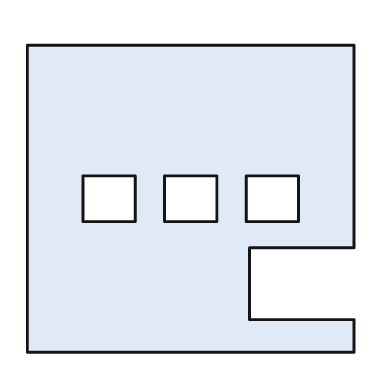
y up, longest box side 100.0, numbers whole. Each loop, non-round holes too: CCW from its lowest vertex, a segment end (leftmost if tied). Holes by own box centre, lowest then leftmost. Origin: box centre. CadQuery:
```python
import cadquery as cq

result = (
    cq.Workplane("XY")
    .moveTo(-50.0, -47.0)
    .lineTo(50.0, -47.0)
    .lineTo(50.0, -37.0)
    .lineTo(18.0, -37.0)
    .lineTo(18.0, -15.0)
    .lineTo(50.0, -15.0)
    .lineTo(50.0, 47.0)
    .lineTo(-50.0, 47.0)
    .close()
    .moveTo(-33.0, -7.0)
    .lineTo(-17.0, -7.0)
    .lineTo(-17.0, 7.0)
    .lineTo(-33.0, 7.0)
    .close()
    .moveTo(-8.0, -7.0)
    .lineTo(8.0, -7.0)
    .lineTo(8.0, 7.0)
    .lineTo(-8.0, 7.0)
    .close()
    .moveTo(17.0, -7.0)
    .lineTo(33.0, -7.0)
    .lineTo(33.0, 7.0)
    .lineTo(17.0, 7.0)
    .close()
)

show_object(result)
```